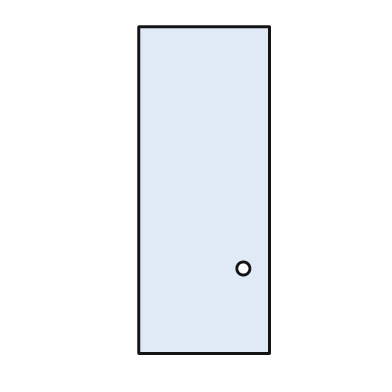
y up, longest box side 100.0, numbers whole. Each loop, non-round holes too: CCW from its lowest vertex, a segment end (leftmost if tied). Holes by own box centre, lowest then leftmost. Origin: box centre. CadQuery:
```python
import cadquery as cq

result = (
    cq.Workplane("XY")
    .moveTo(-20.0, -50.0)
    .lineTo(20.0, -50.0)
    .lineTo(20.0, 50.0)
    .lineTo(-20.0, 50.0)
    .close()
    .moveTo(12.0, -24.0)
    .circle(2.0)
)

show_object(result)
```